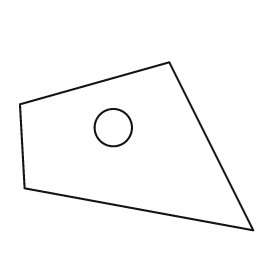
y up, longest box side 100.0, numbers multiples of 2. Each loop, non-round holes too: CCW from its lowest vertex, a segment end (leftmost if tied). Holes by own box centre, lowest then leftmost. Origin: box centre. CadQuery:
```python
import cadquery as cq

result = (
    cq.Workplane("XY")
    .moveTo(50.0, -36.0)
    .lineTo(14.0, 36.0)
    .lineTo(-50.0, 18.0)
    .lineTo(-48.0, -18.0)
    .close()
    .moveTo(-10.0, 8.0)
    .circle(8.0)
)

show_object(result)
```